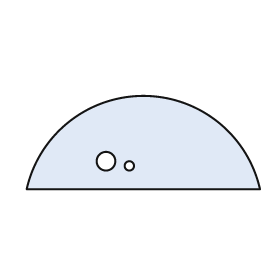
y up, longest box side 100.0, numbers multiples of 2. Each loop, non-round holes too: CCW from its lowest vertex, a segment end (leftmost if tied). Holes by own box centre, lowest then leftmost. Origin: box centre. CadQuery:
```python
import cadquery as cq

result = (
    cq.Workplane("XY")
    .moveTo(-50.0, -20.0)
    .lineTo(50.0, -20.0)
    .threePointArc((0.0, 20.0), (-50.0, -20.0))
    .close()
    .moveTo(-6.0, -10.0)
    .circle(2.0)
    .moveTo(-16.0, -8.0)
    .circle(4.0)
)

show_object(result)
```